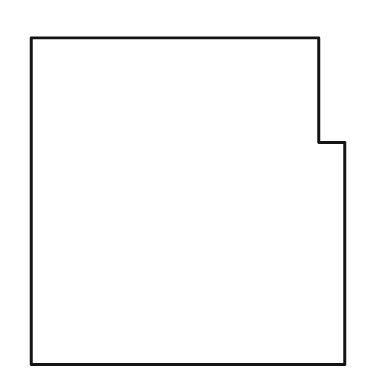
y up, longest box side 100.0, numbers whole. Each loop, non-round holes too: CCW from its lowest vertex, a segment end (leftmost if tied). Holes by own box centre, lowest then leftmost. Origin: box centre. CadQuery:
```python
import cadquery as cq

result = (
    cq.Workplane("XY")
    .moveTo(-48.0, -50.0)
    .lineTo(48.0, -50.0)
    .lineTo(48.0, 18.0)
    .lineTo(40.0, 18.0)
    .lineTo(40.0, 50.0)
    .lineTo(-48.0, 50.0)
    .close()
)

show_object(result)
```